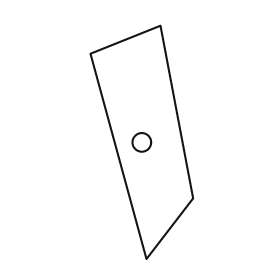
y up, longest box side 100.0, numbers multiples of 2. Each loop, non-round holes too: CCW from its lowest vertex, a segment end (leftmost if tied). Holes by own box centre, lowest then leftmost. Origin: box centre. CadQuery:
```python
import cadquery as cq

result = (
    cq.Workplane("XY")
    .moveTo(2.0, -50.0)
    .lineTo(22.0, -24.0)
    .lineTo(8.0, 50.0)
    .lineTo(-22.0, 38.0)
    .close()
    .moveTo(0.0, 0.0)
    .circle(4.0)
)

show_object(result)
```